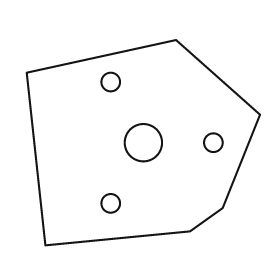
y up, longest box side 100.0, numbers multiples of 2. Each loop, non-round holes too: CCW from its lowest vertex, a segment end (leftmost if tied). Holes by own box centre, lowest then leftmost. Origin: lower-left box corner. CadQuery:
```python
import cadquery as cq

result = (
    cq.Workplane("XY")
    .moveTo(8.0, 0.0)
    .lineTo(70.0, 6.0)
    .lineTo(84.0, 16.0)
    .lineTo(100.0, 56.0)
    .lineTo(64.0, 88.0)
    .lineTo(0.0, 74.0)
    .close()
    .moveTo(36.0, 18.0)
    .circle(4.0)
    .moveTo(50.0, 44.0)
    .circle(8.0)
    .moveTo(80.0, 44.0)
    .circle(4.0)
    .moveTo(36.0, 70.0)
    .circle(4.0)
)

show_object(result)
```